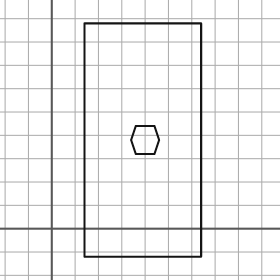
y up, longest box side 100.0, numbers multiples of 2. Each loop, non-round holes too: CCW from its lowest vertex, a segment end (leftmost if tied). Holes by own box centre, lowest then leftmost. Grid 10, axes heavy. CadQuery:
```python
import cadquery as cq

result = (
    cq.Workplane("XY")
    .moveTo(14.0, -12.0)
    .lineTo(64.0, -12.0)
    .lineTo(64.0, 88.0)
    .lineTo(14.0, 88.0)
    .close()
    .moveTo(36.0, 32.0)
    .lineTo(44.0, 32.0)
    .lineTo(46.0, 38.0)
    .lineTo(44.0, 44.0)
    .lineTo(36.0, 44.0)
    .lineTo(34.0, 38.0)
    .close()
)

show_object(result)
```